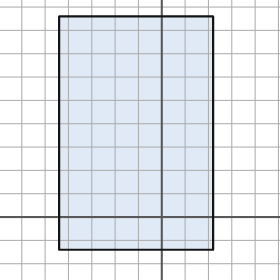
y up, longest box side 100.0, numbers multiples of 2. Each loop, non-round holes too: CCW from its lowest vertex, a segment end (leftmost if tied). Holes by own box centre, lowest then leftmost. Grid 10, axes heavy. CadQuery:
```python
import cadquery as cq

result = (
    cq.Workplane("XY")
    .moveTo(-44.0, -14.0)
    .lineTo(22.0, -14.0)
    .lineTo(22.0, 86.0)
    .lineTo(-44.0, 86.0)
    .close()
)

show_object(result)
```